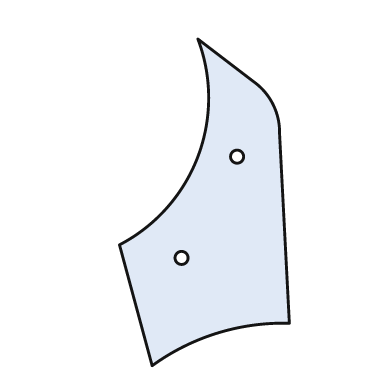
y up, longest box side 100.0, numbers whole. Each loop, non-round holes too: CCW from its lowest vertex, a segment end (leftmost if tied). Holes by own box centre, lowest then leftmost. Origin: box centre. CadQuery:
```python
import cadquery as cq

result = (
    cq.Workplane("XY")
    .moveTo(-16.0, -50.0)
    .threePointArc((4.0, -40.0), (26.0, -37.0))
    .lineTo(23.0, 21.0)
    .threePointArc((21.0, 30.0), (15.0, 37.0))
    .lineTo(-2.0, 50.0)
    .threePointArc((-2.0, 14.0), (-26.0, -13.0))
    .close()
    .moveTo(-7.0, -17.0)
    .circle(2.0)
    .moveTo(10.0, 14.0)
    .circle(2.0)
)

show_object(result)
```